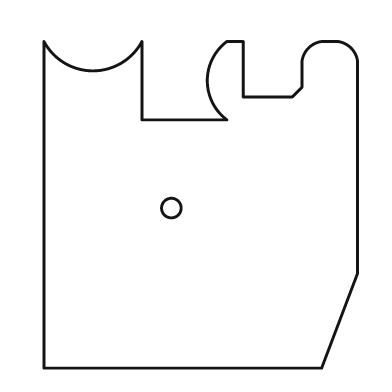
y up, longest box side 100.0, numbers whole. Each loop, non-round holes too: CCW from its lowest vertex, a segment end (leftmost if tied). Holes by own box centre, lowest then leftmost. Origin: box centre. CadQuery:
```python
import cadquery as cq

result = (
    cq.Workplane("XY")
    .moveTo(-48.0, -50.0)
    .lineTo(37.0, -50.0)
    .lineTo(48.0, -21.0)
    .lineTo(48.0, 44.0)
    .threePointArc((46.0, 48.0), (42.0, 50.0))
    .lineTo(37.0, 50.0)
    .threePointArc((33.0, 48.0), (31.0, 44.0))
    .lineTo(31.0, 36.0)
    .lineTo(28.0, 33.0)
    .lineTo(13.0, 33.0)
    .lineTo(13.0, 50.0)
    .lineTo(8.0, 50.0)
    .threePointArc((2.0, 38.0), (8.0, 26.0))
    .lineTo(-18.0, 26.0)
    .lineTo(-18.0, 50.0)
    .threePointArc((-33.0, 41.0), (-48.0, 50.0))
    .close()
    .moveTo(-9.0, -1.0)
    .circle(3.0)
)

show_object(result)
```